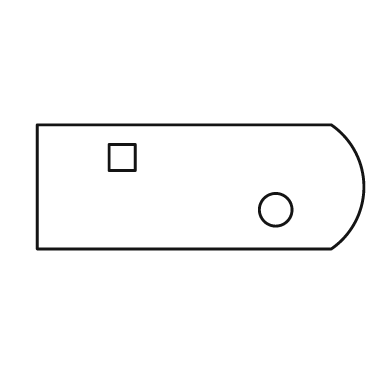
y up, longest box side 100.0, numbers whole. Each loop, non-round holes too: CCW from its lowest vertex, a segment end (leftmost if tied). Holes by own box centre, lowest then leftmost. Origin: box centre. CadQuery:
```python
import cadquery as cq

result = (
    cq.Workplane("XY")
    .moveTo(-50.0, -19.0)
    .lineTo(40.0, -19.0)
    .threePointArc((50.0, 0.0), (40.0, 19.0))
    .lineTo(-50.0, 19.0)
    .close()
    .moveTo(23.0, -7.0)
    .circle(5.0)
    .moveTo(-28.0, 5.0)
    .lineTo(-20.0, 5.0)
    .lineTo(-20.0, 13.0)
    .lineTo(-28.0, 13.0)
    .close()
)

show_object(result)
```